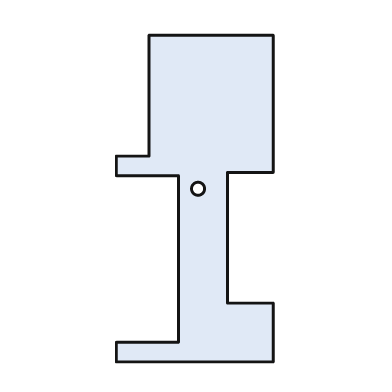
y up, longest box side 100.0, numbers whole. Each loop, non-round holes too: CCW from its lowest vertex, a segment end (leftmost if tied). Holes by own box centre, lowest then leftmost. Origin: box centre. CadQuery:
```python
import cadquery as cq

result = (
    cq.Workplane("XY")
    .moveTo(-24.0, -50.0)
    .lineTo(24.0, -50.0)
    .lineTo(24.0, -32.0)
    .lineTo(10.0, -32.0)
    .lineTo(10.0, 8.0)
    .lineTo(24.0, 8.0)
    .lineTo(24.0, 50.0)
    .lineTo(-14.0, 50.0)
    .lineTo(-14.0, 13.0)
    .lineTo(-24.0, 13.0)
    .lineTo(-24.0, 7.0)
    .lineTo(-5.0, 7.0)
    .lineTo(-5.0, -44.0)
    .lineTo(-24.0, -44.0)
    .close()
    .moveTo(1.0, 3.0)
    .circle(2.0)
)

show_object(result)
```